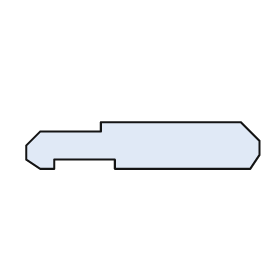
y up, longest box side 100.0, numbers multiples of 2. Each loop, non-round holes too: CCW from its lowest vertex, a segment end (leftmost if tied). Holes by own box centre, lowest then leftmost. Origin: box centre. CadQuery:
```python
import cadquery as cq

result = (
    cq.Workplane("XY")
    .moveTo(-44.0, -10.0)
    .lineTo(-38.0, -10.0)
    .lineTo(-38.0, -6.0)
    .lineTo(-12.0, -6.0)
    .lineTo(-12.0, -10.0)
    .lineTo(46.0, -10.0)
    .lineTo(50.0, -4.0)
    .lineTo(50.0, 2.0)
    .lineTo(42.0, 10.0)
    .lineTo(-18.0, 10.0)
    .lineTo(-18.0, 6.0)
    .lineTo(-44.0, 6.0)
    .lineTo(-50.0, 0.0)
    .lineTo(-50.0, -6.0)
    .close()
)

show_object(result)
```